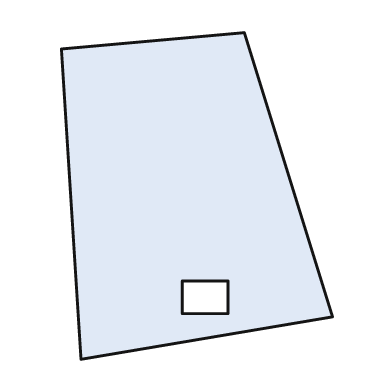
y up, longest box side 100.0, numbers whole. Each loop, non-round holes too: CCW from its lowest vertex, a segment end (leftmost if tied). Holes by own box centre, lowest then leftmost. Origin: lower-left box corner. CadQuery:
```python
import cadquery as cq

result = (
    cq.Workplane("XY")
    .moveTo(6.0, 0.0)
    .lineTo(83.0, 13.0)
    .lineTo(56.0, 100.0)
    .lineTo(0.0, 95.0)
    .close()
    .moveTo(37.0, 14.0)
    .lineTo(51.0, 14.0)
    .lineTo(51.0, 24.0)
    .lineTo(37.0, 24.0)
    .close()
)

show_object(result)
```